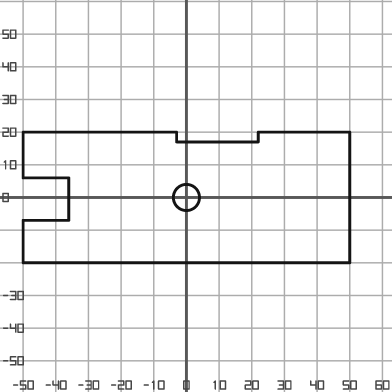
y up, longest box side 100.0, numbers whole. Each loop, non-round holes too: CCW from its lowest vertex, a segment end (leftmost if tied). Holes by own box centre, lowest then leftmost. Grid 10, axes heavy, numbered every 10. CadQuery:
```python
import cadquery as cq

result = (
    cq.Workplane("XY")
    .moveTo(-50.0, -20.0)
    .lineTo(50.0, -20.0)
    .lineTo(50.0, 20.0)
    .lineTo(22.0, 20.0)
    .lineTo(22.0, 17.0)
    .lineTo(-3.0, 17.0)
    .lineTo(-3.0, 20.0)
    .lineTo(-50.0, 20.0)
    .lineTo(-50.0, 6.0)
    .lineTo(-36.0, 6.0)
    .lineTo(-36.0, -7.0)
    .lineTo(-50.0, -7.0)
    .close()
    .moveTo(0.0, 0.0)
    .circle(4.0)
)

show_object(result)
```